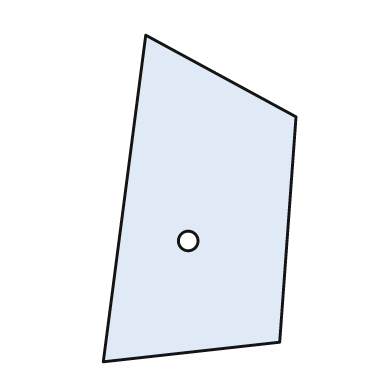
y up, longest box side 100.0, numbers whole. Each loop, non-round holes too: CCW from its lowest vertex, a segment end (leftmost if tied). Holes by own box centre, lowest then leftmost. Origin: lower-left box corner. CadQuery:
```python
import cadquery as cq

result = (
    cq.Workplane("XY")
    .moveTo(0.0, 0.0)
    .lineTo(54.0, 6.0)
    .lineTo(59.0, 75.0)
    .lineTo(13.0, 100.0)
    .close()
    .moveTo(26.0, 37.0)
    .circle(3.0)
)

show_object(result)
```